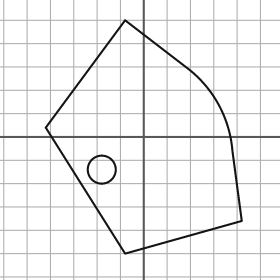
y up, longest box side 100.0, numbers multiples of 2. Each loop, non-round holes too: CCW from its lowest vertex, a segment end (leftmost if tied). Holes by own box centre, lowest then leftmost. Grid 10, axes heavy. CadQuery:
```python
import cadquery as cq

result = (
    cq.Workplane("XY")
    .moveTo(-8.0, -50.0)
    .lineTo(42.0, -36.0)
    .lineTo(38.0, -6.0)
    .threePointArc((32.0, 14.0), (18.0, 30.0))
    .lineTo(-8.0, 50.0)
    .lineTo(-42.0, 4.0)
    .close()
    .moveTo(-18.0, -14.0)
    .circle(6.0)
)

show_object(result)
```